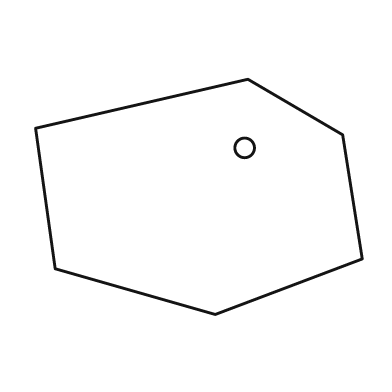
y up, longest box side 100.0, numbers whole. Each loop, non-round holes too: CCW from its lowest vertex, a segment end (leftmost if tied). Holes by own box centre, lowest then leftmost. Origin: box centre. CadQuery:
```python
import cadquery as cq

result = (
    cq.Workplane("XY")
    .moveTo(5.0, -36.0)
    .lineTo(50.0, -19.0)
    .lineTo(44.0, 19.0)
    .lineTo(15.0, 36.0)
    .lineTo(-50.0, 21.0)
    .lineTo(-44.0, -22.0)
    .close()
    .moveTo(14.0, 15.0)
    .circle(3.0)
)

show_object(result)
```